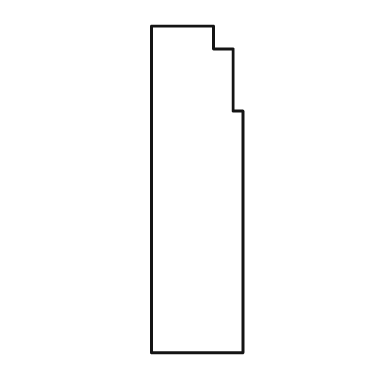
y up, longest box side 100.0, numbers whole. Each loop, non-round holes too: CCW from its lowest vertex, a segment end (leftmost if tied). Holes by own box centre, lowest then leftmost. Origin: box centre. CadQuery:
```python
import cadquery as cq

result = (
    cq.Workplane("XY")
    .moveTo(-14.0, -50.0)
    .lineTo(14.0, -50.0)
    .lineTo(14.0, 24.0)
    .lineTo(11.0, 24.0)
    .lineTo(11.0, 43.0)
    .lineTo(5.0, 43.0)
    .lineTo(5.0, 50.0)
    .lineTo(-14.0, 50.0)
    .close()
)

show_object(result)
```